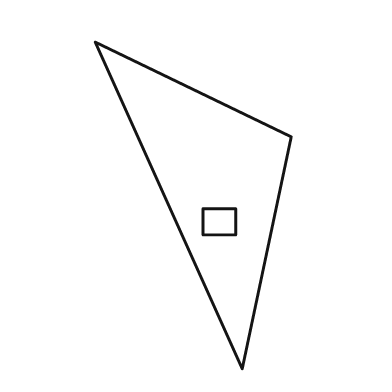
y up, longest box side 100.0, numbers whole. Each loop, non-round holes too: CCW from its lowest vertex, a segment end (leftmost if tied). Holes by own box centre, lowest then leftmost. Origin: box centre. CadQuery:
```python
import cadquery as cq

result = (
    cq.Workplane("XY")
    .moveTo(15.0, -50.0)
    .lineTo(30.0, 21.0)
    .lineTo(-30.0, 50.0)
    .close()
    .moveTo(3.0, -9.0)
    .lineTo(13.0, -9.0)
    .lineTo(13.0, -1.0)
    .lineTo(3.0, -1.0)
    .close()
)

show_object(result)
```